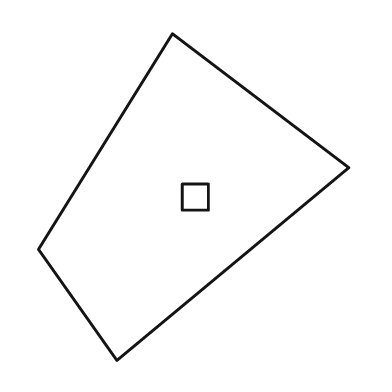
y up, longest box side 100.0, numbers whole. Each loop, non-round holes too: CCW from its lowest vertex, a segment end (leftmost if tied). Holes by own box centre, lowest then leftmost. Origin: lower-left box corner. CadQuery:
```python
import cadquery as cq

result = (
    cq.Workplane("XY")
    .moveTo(24.0, 0.0)
    .lineTo(95.0, 59.0)
    .lineTo(41.0, 100.0)
    .lineTo(0.0, 34.0)
    .close()
    .moveTo(44.0, 46.0)
    .lineTo(52.0, 46.0)
    .lineTo(52.0, 54.0)
    .lineTo(44.0, 54.0)
    .close()
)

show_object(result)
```